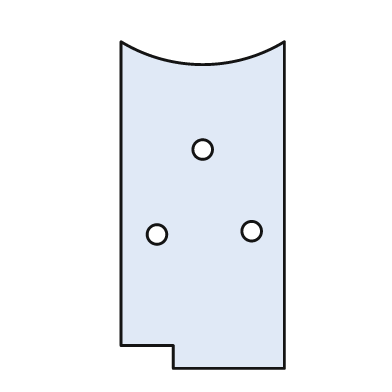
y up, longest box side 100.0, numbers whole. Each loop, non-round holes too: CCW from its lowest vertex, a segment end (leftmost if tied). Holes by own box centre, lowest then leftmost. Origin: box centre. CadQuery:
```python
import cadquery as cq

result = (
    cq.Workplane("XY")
    .moveTo(-9.0, -50.0)
    .lineTo(25.0, -50.0)
    .lineTo(25.0, 50.0)
    .threePointArc((0.0, 43.0), (-25.0, 50.0))
    .lineTo(-25.0, -43.0)
    .lineTo(-9.0, -43.0)
    .close()
    .moveTo(-14.0, -9.0)
    .circle(3.0)
    .moveTo(15.0, -8.0)
    .circle(3.0)
    .moveTo(0.0, 17.0)
    .circle(3.0)
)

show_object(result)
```